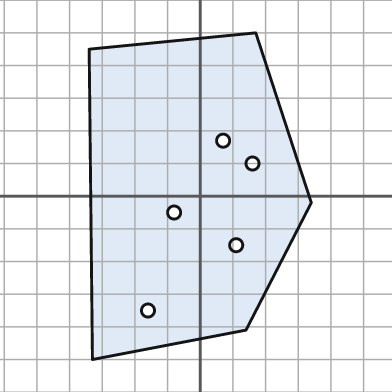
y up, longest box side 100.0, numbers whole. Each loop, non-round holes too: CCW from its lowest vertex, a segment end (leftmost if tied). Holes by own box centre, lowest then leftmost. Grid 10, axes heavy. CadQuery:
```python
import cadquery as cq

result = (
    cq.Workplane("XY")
    .moveTo(-33.0, -50.0)
    .lineTo(14.0, -41.0)
    .lineTo(34.0, -2.0)
    .lineTo(17.0, 50.0)
    .lineTo(-34.0, 45.0)
    .close()
    .moveTo(-16.0, -35.0)
    .circle(2.0)
    .moveTo(11.0, -15.0)
    .circle(2.0)
    .moveTo(-8.0, -5.0)
    .circle(2.0)
    .moveTo(16.0, 10.0)
    .circle(2.0)
    .moveTo(7.0, 17.0)
    .circle(2.0)
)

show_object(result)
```